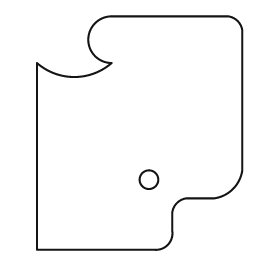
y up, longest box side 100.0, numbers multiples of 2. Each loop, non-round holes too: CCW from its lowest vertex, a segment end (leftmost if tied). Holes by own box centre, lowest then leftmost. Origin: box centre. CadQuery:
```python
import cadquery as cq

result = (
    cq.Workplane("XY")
    .moveTo(-44.0, -50.0)
    .lineTo(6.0, -50.0)
    .threePointArc((12.0, -48.0), (14.0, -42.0))
    .lineTo(14.0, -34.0)
    .threePointArc((16.0, -30.0), (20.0, -28.0))
    .lineTo(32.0, -28.0)
    .threePointArc((40.0, -24.0), (44.0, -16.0))
    .lineTo(44.0, 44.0)
    .threePointArc((42.0, 48.0), (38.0, 50.0))
    .lineTo(-12.0, 50.0)
    .threePointArc((-22.0, 40.0), (-12.0, 30.0))
    .threePointArc((-28.0, 24.0), (-44.0, 30.0))
    .close()
    .moveTo(4.0, -20.0)
    .circle(4.0)
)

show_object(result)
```